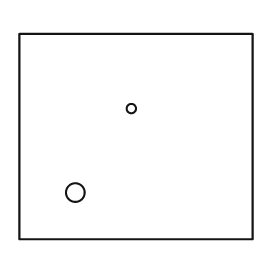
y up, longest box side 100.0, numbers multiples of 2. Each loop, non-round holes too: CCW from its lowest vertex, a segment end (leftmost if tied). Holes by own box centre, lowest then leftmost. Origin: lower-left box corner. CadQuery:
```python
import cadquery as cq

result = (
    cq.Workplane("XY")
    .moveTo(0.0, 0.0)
    .lineTo(100.0, 0.0)
    .lineTo(100.0, 88.0)
    .lineTo(0.0, 88.0)
    .close()
    .moveTo(24.0, 20.0)
    .circle(4.0)
    .moveTo(48.0, 56.0)
    .circle(2.0)
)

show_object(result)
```